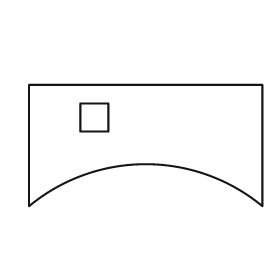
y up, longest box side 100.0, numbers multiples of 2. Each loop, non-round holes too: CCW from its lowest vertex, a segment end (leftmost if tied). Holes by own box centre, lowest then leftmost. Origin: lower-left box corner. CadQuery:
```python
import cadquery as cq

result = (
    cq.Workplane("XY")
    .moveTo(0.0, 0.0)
    .threePointArc((50.0, 18.0), (100.0, 0.0))
    .lineTo(100.0, 52.0)
    .lineTo(0.0, 52.0)
    .close()
    .moveTo(22.0, 32.0)
    .lineTo(34.0, 32.0)
    .lineTo(34.0, 44.0)
    .lineTo(22.0, 44.0)
    .close()
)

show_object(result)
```